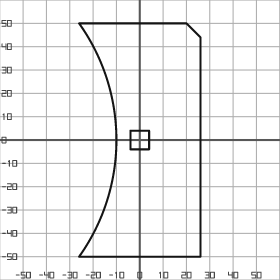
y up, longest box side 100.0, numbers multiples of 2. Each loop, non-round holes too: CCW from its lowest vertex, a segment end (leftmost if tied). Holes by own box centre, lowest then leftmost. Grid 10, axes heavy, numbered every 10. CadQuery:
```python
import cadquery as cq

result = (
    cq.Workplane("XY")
    .moveTo(-26.0, -50.0)
    .lineTo(26.0, -50.0)
    .lineTo(26.0, 44.0)
    .lineTo(20.0, 50.0)
    .lineTo(-26.0, 50.0)
    .threePointArc((-10.0, 0.0), (-26.0, -50.0))
    .close()
    .moveTo(-4.0, -4.0)
    .lineTo(4.0, -4.0)
    .lineTo(4.0, 4.0)
    .lineTo(-4.0, 4.0)
    .close()
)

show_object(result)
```